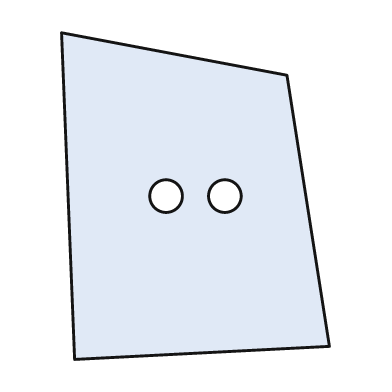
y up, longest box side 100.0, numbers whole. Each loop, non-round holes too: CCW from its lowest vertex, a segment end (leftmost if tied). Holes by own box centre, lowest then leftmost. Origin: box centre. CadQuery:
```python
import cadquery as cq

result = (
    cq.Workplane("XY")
    .moveTo(-37.0, -50.0)
    .lineTo(41.0, -46.0)
    .lineTo(28.0, 37.0)
    .lineTo(-41.0, 50.0)
    .close()
    .moveTo(-9.0, 0.0)
    .circle(5.0)
    .moveTo(9.0, 0.0)
    .circle(5.0)
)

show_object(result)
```